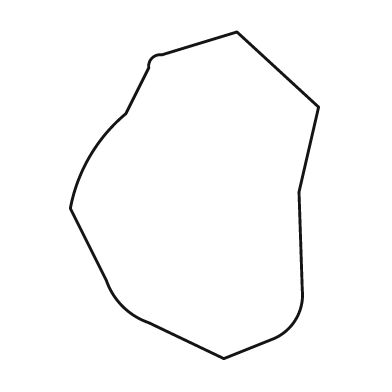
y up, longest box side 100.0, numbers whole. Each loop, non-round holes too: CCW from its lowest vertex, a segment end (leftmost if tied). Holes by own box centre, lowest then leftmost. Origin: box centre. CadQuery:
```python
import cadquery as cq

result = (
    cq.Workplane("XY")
    .moveTo(9.0, -50.0)
    .lineTo(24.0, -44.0)
    .threePointArc((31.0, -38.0), (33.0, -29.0))
    .lineTo(32.0, 1.0)
    .lineTo(38.0, 27.0)
    .lineTo(13.0, 50.0)
    .lineTo(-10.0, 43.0)
    .threePointArc((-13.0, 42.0), (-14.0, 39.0))
    .lineTo(-21.0, 25.0)
    .threePointArc((-32.0, 12.0), (-38.0, -4.0))
    .lineTo(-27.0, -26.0)
    .threePointArc((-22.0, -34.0), (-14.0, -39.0))
    .close()
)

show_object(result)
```